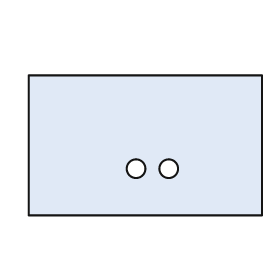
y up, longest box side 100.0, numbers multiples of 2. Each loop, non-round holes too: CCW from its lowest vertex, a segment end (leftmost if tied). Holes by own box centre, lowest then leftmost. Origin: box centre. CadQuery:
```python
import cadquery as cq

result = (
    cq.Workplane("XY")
    .moveTo(-50.0, -30.0)
    .lineTo(50.0, -30.0)
    .lineTo(50.0, 30.0)
    .lineTo(-50.0, 30.0)
    .close()
    .moveTo(-4.0, -10.0)
    .circle(4.0)
    .moveTo(10.0, -10.0)
    .circle(4.0)
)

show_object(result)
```